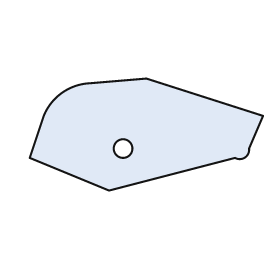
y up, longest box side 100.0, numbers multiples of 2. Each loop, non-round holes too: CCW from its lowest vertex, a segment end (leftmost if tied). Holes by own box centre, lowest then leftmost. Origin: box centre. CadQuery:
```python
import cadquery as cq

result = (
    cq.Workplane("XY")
    .moveTo(-16.0, -24.0)
    .lineTo(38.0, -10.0)
    .threePointArc((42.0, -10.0), (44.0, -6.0))
    .lineTo(50.0, 8.0)
    .lineTo(0.0, 24.0)
    .lineTo(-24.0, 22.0)
    .threePointArc((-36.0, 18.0), (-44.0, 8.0))
    .lineTo(-50.0, -10.0)
    .close()
    .moveTo(-10.0, -6.0)
    .circle(4.0)
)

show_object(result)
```